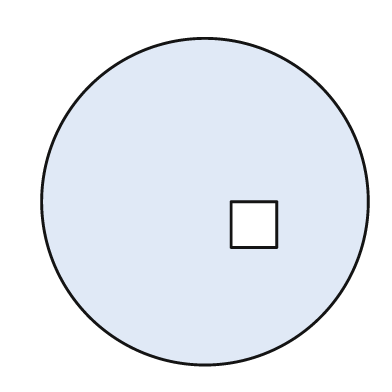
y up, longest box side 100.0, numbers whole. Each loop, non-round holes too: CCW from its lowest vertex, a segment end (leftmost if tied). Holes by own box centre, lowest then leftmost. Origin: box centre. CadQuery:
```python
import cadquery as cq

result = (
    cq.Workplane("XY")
    .moveTo(0.0, 0.0)
    .circle(50.0)
    .moveTo(8.0, -14.0)
    .lineTo(22.0, -14.0)
    .lineTo(22.0, 0.0)
    .lineTo(8.0, 0.0)
    .close()
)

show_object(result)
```